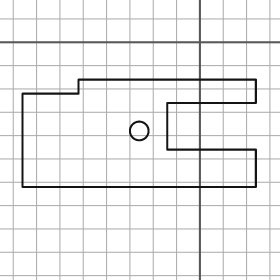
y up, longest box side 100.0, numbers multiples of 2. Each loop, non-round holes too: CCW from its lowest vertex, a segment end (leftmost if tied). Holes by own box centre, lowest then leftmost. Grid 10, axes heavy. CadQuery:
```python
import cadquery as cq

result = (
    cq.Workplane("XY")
    .moveTo(-76.0, -62.0)
    .lineTo(24.0, -62.0)
    .lineTo(24.0, -46.0)
    .lineTo(-14.0, -46.0)
    .lineTo(-14.0, -26.0)
    .lineTo(24.0, -26.0)
    .lineTo(24.0, -16.0)
    .lineTo(-52.0, -16.0)
    .lineTo(-52.0, -22.0)
    .lineTo(-76.0, -22.0)
    .close()
    .moveTo(-26.0, -38.0)
    .circle(4.0)
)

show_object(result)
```